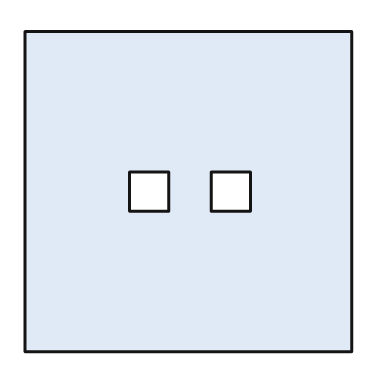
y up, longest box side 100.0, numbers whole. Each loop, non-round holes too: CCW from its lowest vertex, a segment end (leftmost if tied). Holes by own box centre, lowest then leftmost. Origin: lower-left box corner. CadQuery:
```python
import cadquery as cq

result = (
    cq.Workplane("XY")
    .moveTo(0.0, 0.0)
    .lineTo(100.0, 0.0)
    .lineTo(100.0, 98.0)
    .lineTo(0.0, 98.0)
    .close()
    .moveTo(32.0, 43.0)
    .lineTo(44.0, 43.0)
    .lineTo(44.0, 55.0)
    .lineTo(32.0, 55.0)
    .close()
    .moveTo(57.0, 43.0)
    .lineTo(69.0, 43.0)
    .lineTo(69.0, 55.0)
    .lineTo(57.0, 55.0)
    .close()
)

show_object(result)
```